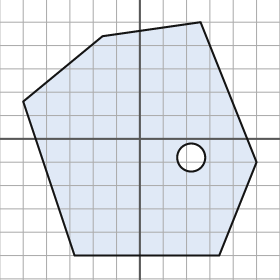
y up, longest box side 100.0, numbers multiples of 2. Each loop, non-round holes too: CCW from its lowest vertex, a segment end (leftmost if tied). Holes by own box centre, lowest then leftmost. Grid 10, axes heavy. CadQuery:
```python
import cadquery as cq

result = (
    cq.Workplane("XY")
    .moveTo(-28.0, -50.0)
    .lineTo(34.0, -50.0)
    .lineTo(50.0, -10.0)
    .lineTo(26.0, 50.0)
    .lineTo(-16.0, 44.0)
    .lineTo(-50.0, 16.0)
    .close()
    .moveTo(22.0, -8.0)
    .circle(6.0)
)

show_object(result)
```